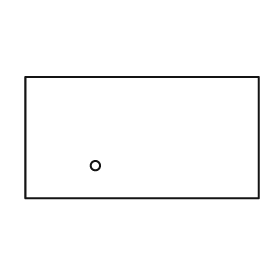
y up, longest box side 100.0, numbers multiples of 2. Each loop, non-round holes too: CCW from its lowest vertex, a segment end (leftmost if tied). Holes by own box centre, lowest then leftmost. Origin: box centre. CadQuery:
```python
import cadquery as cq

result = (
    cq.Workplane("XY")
    .moveTo(-50.0, -26.0)
    .lineTo(50.0, -26.0)
    .lineTo(50.0, 26.0)
    .lineTo(-50.0, 26.0)
    .close()
    .moveTo(-20.0, -12.0)
    .circle(2.0)
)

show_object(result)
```